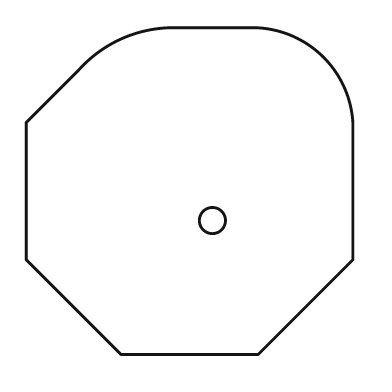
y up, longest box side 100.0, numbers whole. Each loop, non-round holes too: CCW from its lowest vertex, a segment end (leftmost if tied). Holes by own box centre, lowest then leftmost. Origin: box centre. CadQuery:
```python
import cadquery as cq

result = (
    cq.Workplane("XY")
    .moveTo(-21.0, -50.0)
    .lineTo(21.0, -50.0)
    .lineTo(50.0, -21.0)
    .lineTo(50.0, 21.0)
    .threePointArc((41.0, 41.0), (21.0, 50.0))
    .lineTo(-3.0, 50.0)
    .threePointArc((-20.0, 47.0), (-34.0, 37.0))
    .lineTo(-50.0, 21.0)
    .lineTo(-50.0, -21.0)
    .close()
    .moveTo(7.0, -9.0)
    .circle(4.0)
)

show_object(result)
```